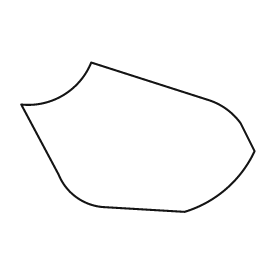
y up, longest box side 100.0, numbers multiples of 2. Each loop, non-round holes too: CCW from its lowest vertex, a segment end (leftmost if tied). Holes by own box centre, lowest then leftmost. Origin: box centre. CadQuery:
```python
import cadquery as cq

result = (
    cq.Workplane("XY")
    .moveTo(20.0, -32.0)
    .threePointArc((38.0, -22.0), (50.0, -6.0))
    .lineTo(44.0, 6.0)
    .threePointArc((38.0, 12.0), (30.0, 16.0))
    .lineTo(-20.0, 32.0)
    .threePointArc((-32.0, 18.0), (-50.0, 14.0))
    .lineTo(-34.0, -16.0)
    .threePointArc((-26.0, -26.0), (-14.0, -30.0))
    .close()
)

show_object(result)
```